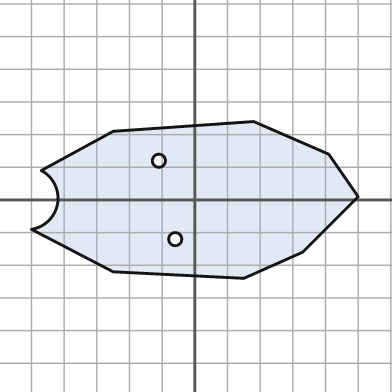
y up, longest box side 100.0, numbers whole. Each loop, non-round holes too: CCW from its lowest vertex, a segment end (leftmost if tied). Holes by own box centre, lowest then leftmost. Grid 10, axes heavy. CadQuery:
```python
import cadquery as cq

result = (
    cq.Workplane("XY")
    .moveTo(15.0, -24.0)
    .lineTo(33.0, -16.0)
    .lineTo(50.0, 1.0)
    .lineTo(41.0, 14.0)
    .lineTo(18.0, 24.0)
    .lineTo(-25.0, 21.0)
    .lineTo(-47.0, 9.0)
    .threePointArc((-42.0, -1.0), (-50.0, -9.0))
    .lineTo(-25.0, -22.0)
    .close()
    .moveTo(-6.0, -12.0)
    .circle(2.0)
    .moveTo(-11.0, 12.0)
    .circle(2.0)
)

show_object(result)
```